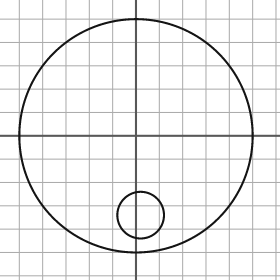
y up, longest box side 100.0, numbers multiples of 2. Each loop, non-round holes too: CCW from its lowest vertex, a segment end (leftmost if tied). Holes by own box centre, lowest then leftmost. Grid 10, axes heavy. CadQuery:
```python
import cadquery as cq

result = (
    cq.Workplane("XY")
    .moveTo(0.0, 0.0)
    .circle(50.0)
    .moveTo(2.0, -34.0)
    .circle(10.0)
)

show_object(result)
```